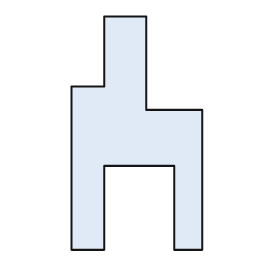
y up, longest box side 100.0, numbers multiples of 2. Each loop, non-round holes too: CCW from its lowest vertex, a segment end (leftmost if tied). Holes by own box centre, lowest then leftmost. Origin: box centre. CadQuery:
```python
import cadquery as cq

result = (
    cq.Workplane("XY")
    .moveTo(-28.0, -50.0)
    .lineTo(-14.0, -50.0)
    .lineTo(-14.0, -14.0)
    .lineTo(16.0, -14.0)
    .lineTo(16.0, -50.0)
    .lineTo(28.0, -50.0)
    .lineTo(28.0, 10.0)
    .lineTo(4.0, 10.0)
    .lineTo(4.0, 50.0)
    .lineTo(-14.0, 50.0)
    .lineTo(-14.0, 20.0)
    .lineTo(-28.0, 20.0)
    .close()
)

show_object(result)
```